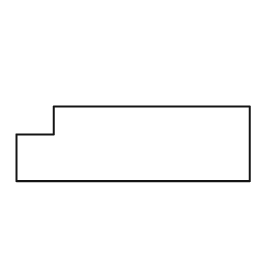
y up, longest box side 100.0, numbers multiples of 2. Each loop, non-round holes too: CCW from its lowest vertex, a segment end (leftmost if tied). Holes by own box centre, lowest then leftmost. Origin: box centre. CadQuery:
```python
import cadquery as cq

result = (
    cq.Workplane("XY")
    .moveTo(-50.0, -16.0)
    .lineTo(50.0, -16.0)
    .lineTo(50.0, 16.0)
    .lineTo(-34.0, 16.0)
    .lineTo(-34.0, 4.0)
    .lineTo(-50.0, 4.0)
    .close()
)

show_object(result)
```